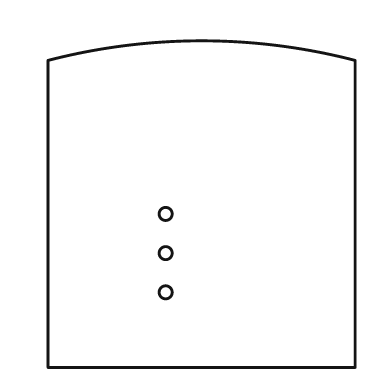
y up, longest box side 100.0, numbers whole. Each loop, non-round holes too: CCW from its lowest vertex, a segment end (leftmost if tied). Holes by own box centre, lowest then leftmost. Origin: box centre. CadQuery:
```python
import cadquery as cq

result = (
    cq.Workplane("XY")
    .moveTo(-47.0, -50.0)
    .lineTo(47.0, -50.0)
    .lineTo(47.0, 44.0)
    .threePointArc((0.0, 50.0), (-47.0, 44.0))
    .close()
    .moveTo(-11.0, -27.0)
    .circle(2.0)
    .moveTo(-11.0, -15.0)
    .circle(2.0)
    .moveTo(-11.0, -3.0)
    .circle(2.0)
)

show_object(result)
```